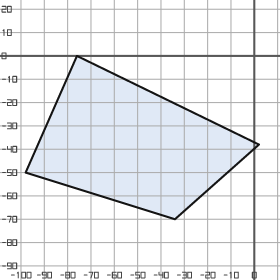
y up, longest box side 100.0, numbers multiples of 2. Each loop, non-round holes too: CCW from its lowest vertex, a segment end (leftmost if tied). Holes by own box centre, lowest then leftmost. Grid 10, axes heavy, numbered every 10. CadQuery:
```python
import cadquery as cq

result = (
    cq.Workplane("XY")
    .moveTo(-34.0, -70.0)
    .lineTo(2.0, -38.0)
    .lineTo(-76.0, 0.0)
    .lineTo(-98.0, -50.0)
    .close()
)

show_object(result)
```